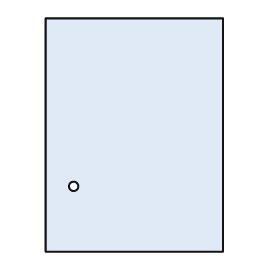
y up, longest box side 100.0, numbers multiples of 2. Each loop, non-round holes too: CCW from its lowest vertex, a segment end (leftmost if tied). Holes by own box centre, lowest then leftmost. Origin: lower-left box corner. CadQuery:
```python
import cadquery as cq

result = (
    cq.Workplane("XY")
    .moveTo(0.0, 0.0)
    .lineTo(76.0, 0.0)
    .lineTo(76.0, 100.0)
    .lineTo(0.0, 100.0)
    .close()
    .moveTo(12.0, 28.0)
    .circle(2.0)
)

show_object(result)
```